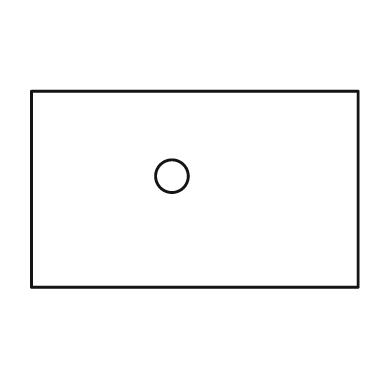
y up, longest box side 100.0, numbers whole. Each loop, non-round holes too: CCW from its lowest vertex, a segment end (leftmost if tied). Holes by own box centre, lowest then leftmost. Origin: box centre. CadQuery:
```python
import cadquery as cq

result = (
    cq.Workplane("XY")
    .moveTo(-50.0, -30.0)
    .lineTo(50.0, -30.0)
    .lineTo(50.0, 30.0)
    .lineTo(-50.0, 30.0)
    .close()
    .moveTo(-7.0, 4.0)
    .circle(5.0)
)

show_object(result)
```